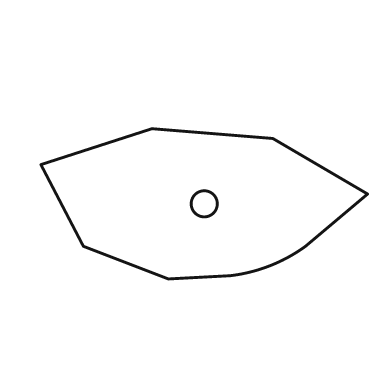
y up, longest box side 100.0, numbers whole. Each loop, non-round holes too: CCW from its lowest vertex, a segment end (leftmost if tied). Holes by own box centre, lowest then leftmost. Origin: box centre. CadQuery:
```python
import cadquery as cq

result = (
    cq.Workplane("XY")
    .moveTo(-11.0, -23.0)
    .lineTo(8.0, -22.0)
    .threePointArc((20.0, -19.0), (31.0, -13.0))
    .lineTo(50.0, 3.0)
    .lineTo(21.0, 20.0)
    .lineTo(-16.0, 23.0)
    .lineTo(-50.0, 12.0)
    .lineTo(-37.0, -13.0)
    .close()
    .moveTo(0.0, 0.0)
    .circle(4.0)
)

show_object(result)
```